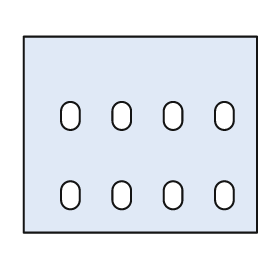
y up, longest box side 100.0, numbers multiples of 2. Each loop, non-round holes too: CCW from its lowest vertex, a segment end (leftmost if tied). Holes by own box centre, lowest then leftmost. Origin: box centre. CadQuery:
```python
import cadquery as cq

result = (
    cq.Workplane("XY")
    .moveTo(-50.0, -42.0)
    .lineTo(50.0, -42.0)
    .lineTo(50.0, 42.0)
    .lineTo(-50.0, 42.0)
    .close()
    .moveTo(-34.0, -28.0)
    .threePointArc((-30.0, -32.0), (-26.0, -28.0))
    .lineTo(-26.0, -24.0)
    .threePointArc((-30.0, -20.0), (-34.0, -24.0))
    .close()
    .moveTo(-12.0, -28.0)
    .threePointArc((-8.0, -32.0), (-4.0, -28.0))
    .lineTo(-4.0, -24.0)
    .threePointArc((-8.0, -20.0), (-12.0, -24.0))
    .close()
    .moveTo(10.0, -28.0)
    .threePointArc((14.0, -32.0), (18.0, -28.0))
    .lineTo(18.0, -24.0)
    .threePointArc((14.0, -20.0), (10.0, -24.0))
    .close()
    .moveTo(32.0, -28.0)
    .threePointArc((36.0, -32.0), (40.0, -28.0))
    .lineTo(40.0, -24.0)
    .threePointArc((36.0, -20.0), (32.0, -24.0))
    .close()
    .moveTo(-34.0, 6.0)
    .threePointArc((-30.0, 2.0), (-26.0, 6.0))
    .lineTo(-26.0, 10.0)
    .threePointArc((-30.0, 14.0), (-34.0, 10.0))
    .close()
    .moveTo(-12.0, 6.0)
    .threePointArc((-8.0, 2.0), (-4.0, 6.0))
    .lineTo(-4.0, 10.0)
    .threePointArc((-8.0, 14.0), (-12.0, 10.0))
    .close()
    .moveTo(10.0, 6.0)
    .threePointArc((14.0, 2.0), (18.0, 6.0))
    .lineTo(18.0, 10.0)
    .threePointArc((14.0, 14.0), (10.0, 10.0))
    .close()
    .moveTo(32.0, 6.0)
    .threePointArc((36.0, 2.0), (40.0, 6.0))
    .lineTo(40.0, 10.0)
    .threePointArc((36.0, 14.0), (32.0, 10.0))
    .close()
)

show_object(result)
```